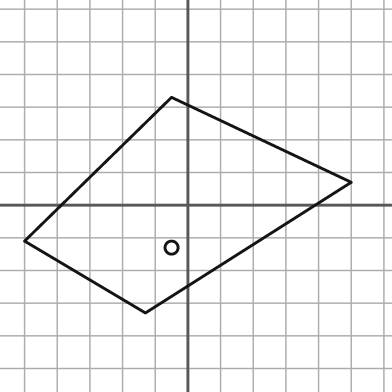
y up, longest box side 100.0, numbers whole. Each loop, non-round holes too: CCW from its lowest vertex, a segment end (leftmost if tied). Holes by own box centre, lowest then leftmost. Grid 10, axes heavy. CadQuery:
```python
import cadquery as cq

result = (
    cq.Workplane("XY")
    .moveTo(-13.0, -33.0)
    .lineTo(50.0, 7.0)
    .lineTo(-5.0, 33.0)
    .lineTo(-50.0, -11.0)
    .close()
    .moveTo(-5.0, -13.0)
    .circle(2.0)
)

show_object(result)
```